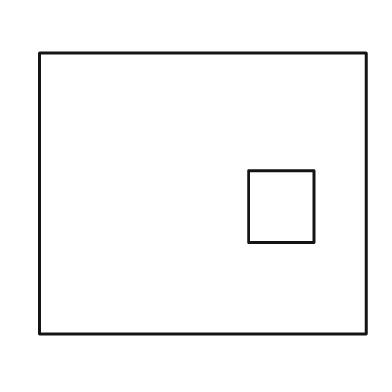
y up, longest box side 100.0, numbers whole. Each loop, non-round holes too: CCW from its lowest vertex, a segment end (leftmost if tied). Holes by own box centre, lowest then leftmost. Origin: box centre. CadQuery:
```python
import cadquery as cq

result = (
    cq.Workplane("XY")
    .moveTo(-50.0, -43.0)
    .lineTo(50.0, -43.0)
    .lineTo(50.0, 43.0)
    .lineTo(-50.0, 43.0)
    .close()
    .moveTo(14.0, -15.0)
    .lineTo(34.0, -15.0)
    .lineTo(34.0, 7.0)
    .lineTo(14.0, 7.0)
    .close()
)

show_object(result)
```